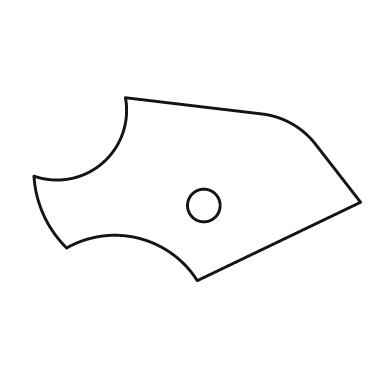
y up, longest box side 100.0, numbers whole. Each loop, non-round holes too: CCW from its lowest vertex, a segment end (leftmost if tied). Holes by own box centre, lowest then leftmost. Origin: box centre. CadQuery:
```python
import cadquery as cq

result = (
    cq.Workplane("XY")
    .moveTo(0.0, -28.0)
    .lineTo(50.0, -4.0)
    .lineTo(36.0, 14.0)
    .threePointArc((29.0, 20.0), (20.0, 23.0))
    .lineTo(-22.0, 28.0)
    .threePointArc((-29.0, 8.0), (-50.0, 4.0))
    .threePointArc((-47.0, -8.0), (-40.0, -18.0))
    .threePointArc((-18.0, -15.0), (0.0, -28.0))
    .close()
    .moveTo(2.0, -5.0)
    .circle(5.0)
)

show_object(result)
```